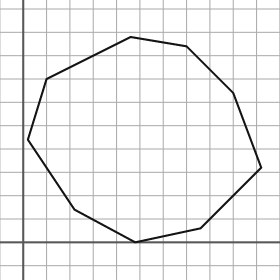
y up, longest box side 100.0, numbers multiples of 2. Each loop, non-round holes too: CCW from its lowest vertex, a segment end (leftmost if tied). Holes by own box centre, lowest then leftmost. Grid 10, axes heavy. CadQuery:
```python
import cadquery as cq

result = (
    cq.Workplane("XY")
    .moveTo(48.0, 0.0)
    .lineTo(76.0, 6.0)
    .lineTo(102.0, 32.0)
    .lineTo(90.0, 64.0)
    .lineTo(70.0, 84.0)
    .lineTo(46.0, 88.0)
    .lineTo(10.0, 70.0)
    .lineTo(2.0, 44.0)
    .lineTo(22.0, 14.0)
    .close()
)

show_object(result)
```